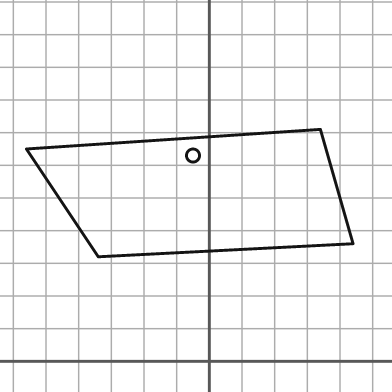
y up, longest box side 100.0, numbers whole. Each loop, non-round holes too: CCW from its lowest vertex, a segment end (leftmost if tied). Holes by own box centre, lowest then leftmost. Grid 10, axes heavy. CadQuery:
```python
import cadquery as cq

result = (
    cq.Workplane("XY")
    .moveTo(-34.0, 32.0)
    .lineTo(44.0, 36.0)
    .lineTo(34.0, 71.0)
    .lineTo(-56.0, 65.0)
    .close()
    .moveTo(-5.0, 63.0)
    .circle(2.0)
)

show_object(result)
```